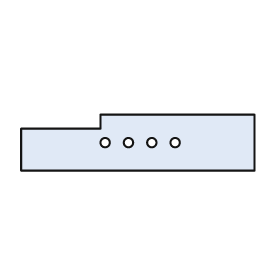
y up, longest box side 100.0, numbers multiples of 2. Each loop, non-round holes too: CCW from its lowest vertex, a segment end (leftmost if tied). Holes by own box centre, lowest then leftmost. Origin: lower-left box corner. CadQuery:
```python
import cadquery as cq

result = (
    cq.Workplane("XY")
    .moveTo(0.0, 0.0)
    .lineTo(100.0, 0.0)
    .lineTo(100.0, 24.0)
    .lineTo(34.0, 24.0)
    .lineTo(34.0, 18.0)
    .lineTo(0.0, 18.0)
    .close()
    .moveTo(36.0, 12.0)
    .circle(2.0)
    .moveTo(46.0, 12.0)
    .circle(2.0)
    .moveTo(56.0, 12.0)
    .circle(2.0)
    .moveTo(66.0, 12.0)
    .circle(2.0)
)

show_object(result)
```